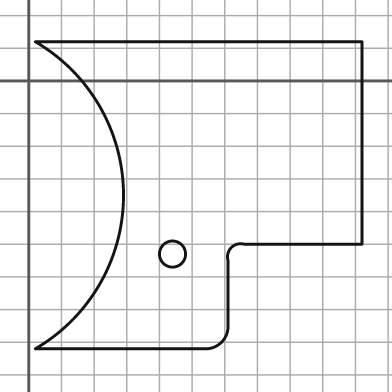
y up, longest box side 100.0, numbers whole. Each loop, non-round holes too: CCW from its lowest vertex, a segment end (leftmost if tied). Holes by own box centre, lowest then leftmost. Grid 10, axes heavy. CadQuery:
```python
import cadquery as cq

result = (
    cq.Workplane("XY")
    .moveTo(2.0, -82.0)
    .lineTo(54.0, -82.0)
    .threePointArc((59.0, -80.0), (61.0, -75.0))
    .lineTo(61.0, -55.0)
    .threePointArc((62.0, -51.0), (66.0, -50.0))
    .lineTo(102.0, -50.0)
    .lineTo(102.0, 12.0)
    .lineTo(2.0, 12.0)
    .threePointArc((29.0, -35.0), (2.0, -82.0))
    .close()
    .moveTo(44.0, -53.0)
    .circle(4.0)
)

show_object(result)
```